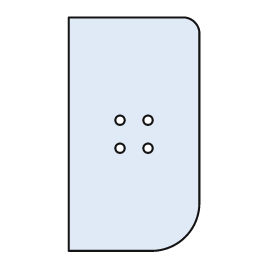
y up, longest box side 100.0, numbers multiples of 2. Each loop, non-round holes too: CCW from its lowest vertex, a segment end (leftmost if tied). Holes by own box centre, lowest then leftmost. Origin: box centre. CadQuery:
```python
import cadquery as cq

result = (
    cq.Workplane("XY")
    .moveTo(-28.0, -50.0)
    .lineTo(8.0, -50.0)
    .threePointArc((22.0, -44.0), (28.0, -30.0))
    .lineTo(28.0, 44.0)
    .threePointArc((26.0, 48.0), (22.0, 50.0))
    .lineTo(-28.0, 50.0)
    .close()
    .moveTo(-6.0, -6.0)
    .circle(2.0)
    .moveTo(6.0, -6.0)
    .circle(2.0)
    .moveTo(-6.0, 6.0)
    .circle(2.0)
    .moveTo(6.0, 6.0)
    .circle(2.0)
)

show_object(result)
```